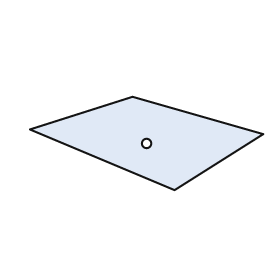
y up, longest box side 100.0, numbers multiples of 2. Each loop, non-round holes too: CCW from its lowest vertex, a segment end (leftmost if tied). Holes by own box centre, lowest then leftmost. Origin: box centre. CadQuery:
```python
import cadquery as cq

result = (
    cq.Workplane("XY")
    .moveTo(12.0, -20.0)
    .lineTo(50.0, 4.0)
    .lineTo(-6.0, 20.0)
    .lineTo(-50.0, 6.0)
    .close()
    .moveTo(0.0, 0.0)
    .circle(2.0)
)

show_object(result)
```